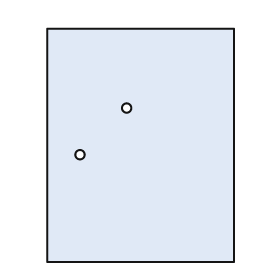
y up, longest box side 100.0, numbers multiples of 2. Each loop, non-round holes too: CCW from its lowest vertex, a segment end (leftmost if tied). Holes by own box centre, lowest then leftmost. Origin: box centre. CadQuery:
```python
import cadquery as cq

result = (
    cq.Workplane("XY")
    .moveTo(-40.0, -50.0)
    .lineTo(40.0, -50.0)
    .lineTo(40.0, 50.0)
    .lineTo(-40.0, 50.0)
    .close()
    .moveTo(-26.0, -4.0)
    .circle(2.0)
    .moveTo(-6.0, 16.0)
    .circle(2.0)
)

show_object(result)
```